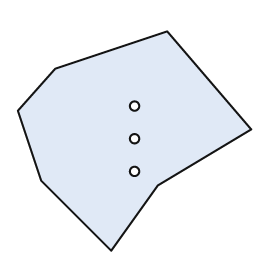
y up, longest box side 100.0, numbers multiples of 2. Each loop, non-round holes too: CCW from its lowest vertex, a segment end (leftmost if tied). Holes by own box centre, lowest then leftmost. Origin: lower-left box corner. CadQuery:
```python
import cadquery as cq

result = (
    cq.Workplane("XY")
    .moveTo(40.0, 0.0)
    .lineTo(60.0, 28.0)
    .lineTo(100.0, 52.0)
    .lineTo(64.0, 94.0)
    .lineTo(16.0, 78.0)
    .lineTo(0.0, 60.0)
    .lineTo(10.0, 30.0)
    .close()
    .moveTo(50.0, 34.0)
    .circle(2.0)
    .moveTo(50.0, 48.0)
    .circle(2.0)
    .moveTo(50.0, 62.0)
    .circle(2.0)
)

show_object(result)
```